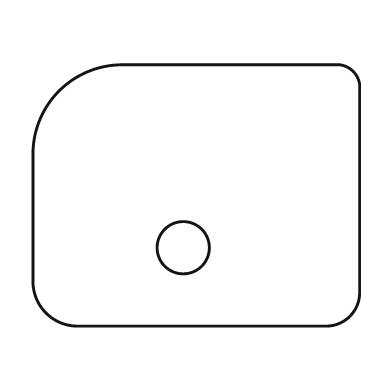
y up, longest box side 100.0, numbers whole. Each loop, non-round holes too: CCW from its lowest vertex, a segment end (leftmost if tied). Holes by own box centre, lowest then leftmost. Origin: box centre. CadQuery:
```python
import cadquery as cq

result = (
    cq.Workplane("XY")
    .moveTo(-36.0, -40.0)
    .lineTo(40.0, -40.0)
    .threePointArc((47.0, -37.0), (50.0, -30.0))
    .lineTo(50.0, 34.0)
    .threePointArc((48.0, 38.0), (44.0, 40.0))
    .lineTo(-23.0, 40.0)
    .threePointArc((-42.0, 32.0), (-50.0, 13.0))
    .lineTo(-50.0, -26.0)
    .threePointArc((-46.0, -36.0), (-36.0, -40.0))
    .close()
    .moveTo(-4.0, -16.0)
    .circle(8.0)
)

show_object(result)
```